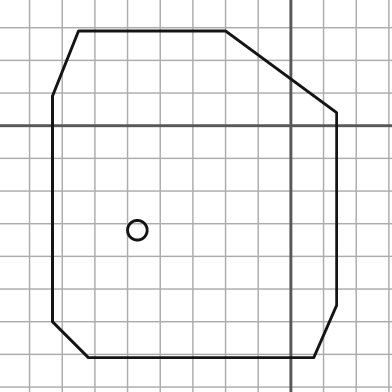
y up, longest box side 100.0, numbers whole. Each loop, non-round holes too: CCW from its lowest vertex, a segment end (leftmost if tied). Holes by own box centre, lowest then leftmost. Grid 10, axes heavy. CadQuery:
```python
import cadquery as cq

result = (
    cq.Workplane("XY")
    .moveTo(-62.0, -71.0)
    .lineTo(7.0, -71.0)
    .lineTo(14.0, -55.0)
    .lineTo(14.0, 4.0)
    .lineTo(-20.0, 29.0)
    .lineTo(-65.0, 29.0)
    .lineTo(-73.0, 9.0)
    .lineTo(-73.0, -60.0)
    .close()
    .moveTo(-47.0, -32.0)
    .circle(3.0)
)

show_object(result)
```